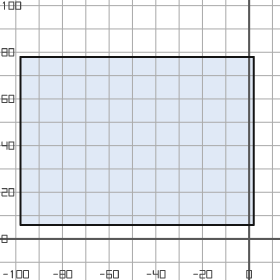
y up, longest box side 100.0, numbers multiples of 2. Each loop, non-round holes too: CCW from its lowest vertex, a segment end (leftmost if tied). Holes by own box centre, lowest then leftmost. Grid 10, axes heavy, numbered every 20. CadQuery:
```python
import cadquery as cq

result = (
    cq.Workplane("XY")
    .moveTo(-98.0, 6.0)
    .lineTo(2.0, 6.0)
    .lineTo(2.0, 78.0)
    .lineTo(-98.0, 78.0)
    .close()
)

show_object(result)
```